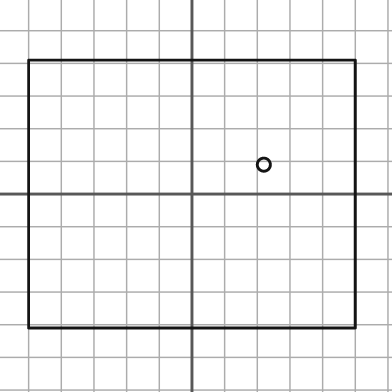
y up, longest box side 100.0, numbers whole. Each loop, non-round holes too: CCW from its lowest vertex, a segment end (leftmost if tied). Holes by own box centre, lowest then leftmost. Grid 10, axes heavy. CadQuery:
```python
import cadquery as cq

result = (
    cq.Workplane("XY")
    .moveTo(-50.0, -41.0)
    .lineTo(50.0, -41.0)
    .lineTo(50.0, 41.0)
    .lineTo(-50.0, 41.0)
    .close()
    .moveTo(22.0, 9.0)
    .circle(2.0)
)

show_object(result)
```